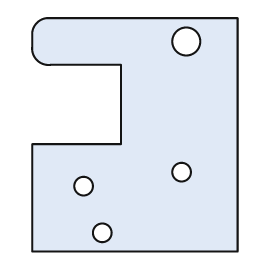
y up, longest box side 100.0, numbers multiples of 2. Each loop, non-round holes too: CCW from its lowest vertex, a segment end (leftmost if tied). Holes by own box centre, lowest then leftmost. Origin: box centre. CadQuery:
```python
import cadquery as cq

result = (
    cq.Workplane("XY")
    .moveTo(-44.0, -50.0)
    .lineTo(44.0, -50.0)
    .lineTo(44.0, 50.0)
    .lineTo(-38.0, 50.0)
    .threePointArc((-42.0, 48.0), (-44.0, 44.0))
    .lineTo(-44.0, 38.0)
    .threePointArc((-42.0, 32.0), (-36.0, 30.0))
    .lineTo(-6.0, 30.0)
    .lineTo(-6.0, -4.0)
    .lineTo(-44.0, -4.0)
    .close()
    .moveTo(-14.0, -42.0)
    .circle(4.0)
    .moveTo(-22.0, -22.0)
    .circle(4.0)
    .moveTo(20.0, -16.0)
    .circle(4.0)
    .moveTo(22.0, 40.0)
    .circle(6.0)
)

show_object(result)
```